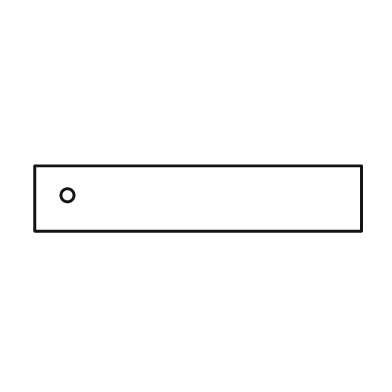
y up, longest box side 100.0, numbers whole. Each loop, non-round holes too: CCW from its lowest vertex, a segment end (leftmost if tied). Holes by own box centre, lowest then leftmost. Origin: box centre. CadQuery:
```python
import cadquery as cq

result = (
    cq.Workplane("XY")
    .moveTo(-50.0, -10.0)
    .lineTo(50.0, -10.0)
    .lineTo(50.0, 10.0)
    .lineTo(-50.0, 10.0)
    .close()
    .moveTo(-40.0, 1.0)
    .circle(2.0)
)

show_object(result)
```